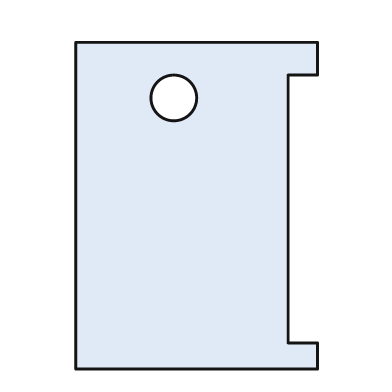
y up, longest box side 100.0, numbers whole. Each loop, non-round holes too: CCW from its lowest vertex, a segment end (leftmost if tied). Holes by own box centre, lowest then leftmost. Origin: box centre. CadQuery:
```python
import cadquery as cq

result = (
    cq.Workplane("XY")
    .moveTo(-37.0, -50.0)
    .lineTo(37.0, -50.0)
    .lineTo(37.0, -42.0)
    .lineTo(28.0, -42.0)
    .lineTo(28.0, 40.0)
    .lineTo(37.0, 40.0)
    .lineTo(37.0, 50.0)
    .lineTo(-37.0, 50.0)
    .close()
    .moveTo(-7.0, 33.0)
    .circle(7.0)
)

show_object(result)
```